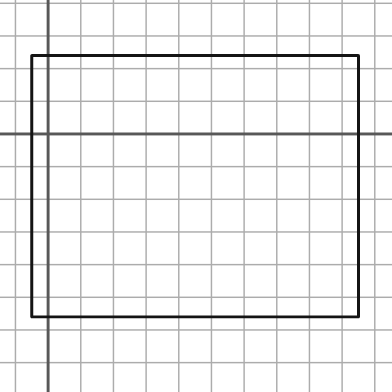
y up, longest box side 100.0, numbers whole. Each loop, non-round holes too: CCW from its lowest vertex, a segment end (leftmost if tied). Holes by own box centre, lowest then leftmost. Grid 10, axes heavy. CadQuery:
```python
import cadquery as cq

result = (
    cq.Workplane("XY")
    .moveTo(-5.0, -56.0)
    .lineTo(95.0, -56.0)
    .lineTo(95.0, 24.0)
    .lineTo(-5.0, 24.0)
    .close()
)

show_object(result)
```